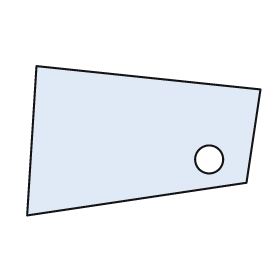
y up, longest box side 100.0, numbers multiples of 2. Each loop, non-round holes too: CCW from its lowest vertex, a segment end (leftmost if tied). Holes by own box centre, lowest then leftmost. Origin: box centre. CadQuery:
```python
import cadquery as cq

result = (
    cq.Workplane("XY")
    .moveTo(-50.0, -32.0)
    .lineTo(44.0, -18.0)
    .lineTo(50.0, 22.0)
    .lineTo(-46.0, 32.0)
    .close()
    .moveTo(28.0, -8.0)
    .circle(6.0)
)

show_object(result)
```